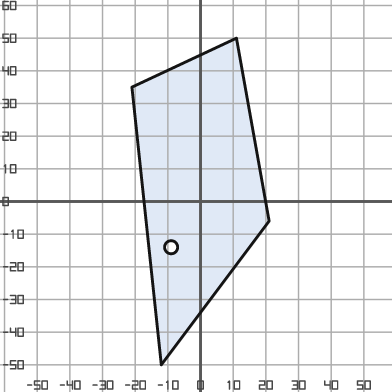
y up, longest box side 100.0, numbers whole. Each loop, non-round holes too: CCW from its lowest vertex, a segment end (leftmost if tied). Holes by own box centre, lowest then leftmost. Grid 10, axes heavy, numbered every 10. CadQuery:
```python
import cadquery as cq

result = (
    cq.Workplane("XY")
    .moveTo(-12.0, -50.0)
    .lineTo(21.0, -6.0)
    .lineTo(11.0, 50.0)
    .lineTo(-21.0, 35.0)
    .close()
    .moveTo(-9.0, -14.0)
    .circle(2.0)
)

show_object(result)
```